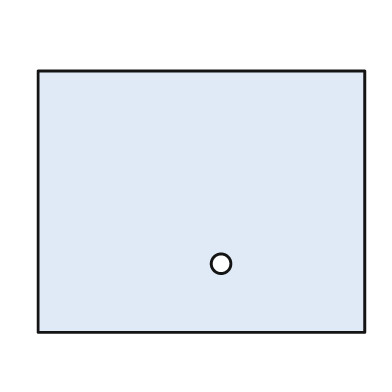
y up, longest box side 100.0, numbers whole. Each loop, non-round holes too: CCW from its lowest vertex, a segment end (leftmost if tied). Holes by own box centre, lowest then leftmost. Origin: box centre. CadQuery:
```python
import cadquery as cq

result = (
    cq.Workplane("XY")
    .moveTo(-50.0, -40.0)
    .lineTo(50.0, -40.0)
    .lineTo(50.0, 40.0)
    .lineTo(-50.0, 40.0)
    .close()
    .moveTo(6.0, -19.0)
    .circle(3.0)
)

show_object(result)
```